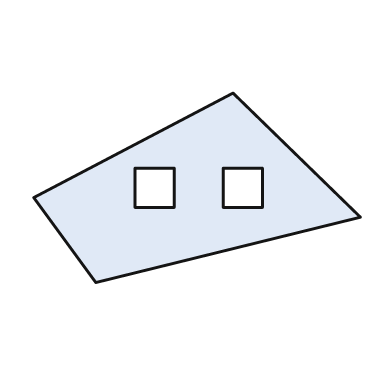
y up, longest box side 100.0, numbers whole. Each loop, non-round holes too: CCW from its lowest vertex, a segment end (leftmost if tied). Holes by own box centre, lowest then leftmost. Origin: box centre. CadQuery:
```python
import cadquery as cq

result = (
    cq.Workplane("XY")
    .moveTo(-31.0, -29.0)
    .lineTo(50.0, -9.0)
    .lineTo(11.0, 29.0)
    .lineTo(-50.0, -3.0)
    .close()
    .moveTo(-19.0, -6.0)
    .lineTo(-7.0, -6.0)
    .lineTo(-7.0, 6.0)
    .lineTo(-19.0, 6.0)
    .close()
    .moveTo(8.0, -6.0)
    .lineTo(20.0, -6.0)
    .lineTo(20.0, 6.0)
    .lineTo(8.0, 6.0)
    .close()
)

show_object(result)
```